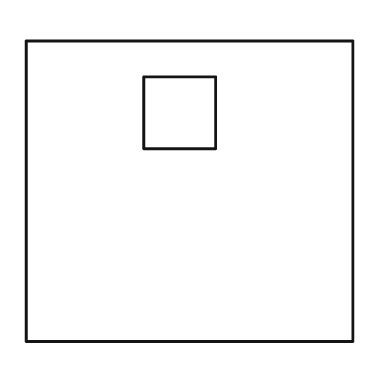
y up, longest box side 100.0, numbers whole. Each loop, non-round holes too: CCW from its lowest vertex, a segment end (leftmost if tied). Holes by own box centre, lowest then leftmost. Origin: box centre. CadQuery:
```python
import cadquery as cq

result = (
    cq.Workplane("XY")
    .moveTo(-50.0, -46.0)
    .lineTo(50.0, -46.0)
    .lineTo(50.0, 46.0)
    .lineTo(-50.0, 46.0)
    .close()
    .moveTo(-14.0, 13.0)
    .lineTo(8.0, 13.0)
    .lineTo(8.0, 35.0)
    .lineTo(-14.0, 35.0)
    .close()
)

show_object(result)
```